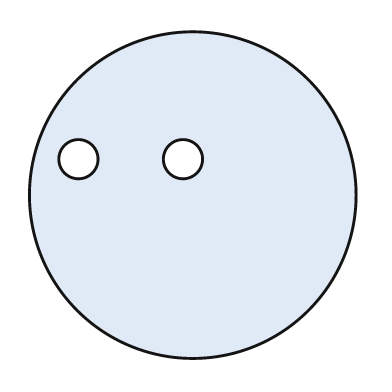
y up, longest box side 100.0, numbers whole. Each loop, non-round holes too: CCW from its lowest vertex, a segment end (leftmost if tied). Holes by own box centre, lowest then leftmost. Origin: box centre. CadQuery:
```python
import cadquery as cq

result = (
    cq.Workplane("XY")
    .moveTo(0.0, 0.0)
    .circle(50.0)
    .moveTo(-35.0, 11.0)
    .circle(6.0)
    .moveTo(-3.0, 11.0)
    .circle(6.0)
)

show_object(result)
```